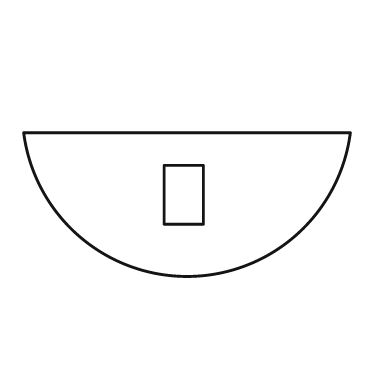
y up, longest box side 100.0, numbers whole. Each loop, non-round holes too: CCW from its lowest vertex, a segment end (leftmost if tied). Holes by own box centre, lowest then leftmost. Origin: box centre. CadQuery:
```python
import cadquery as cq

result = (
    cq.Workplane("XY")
    .moveTo(-50.0, 22.0)
    .threePointArc((0.0, -22.0), (50.0, 22.0))
    .close()
    .moveTo(-7.0, -6.0)
    .lineTo(5.0, -6.0)
    .lineTo(5.0, 12.0)
    .lineTo(-7.0, 12.0)
    .close()
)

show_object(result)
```